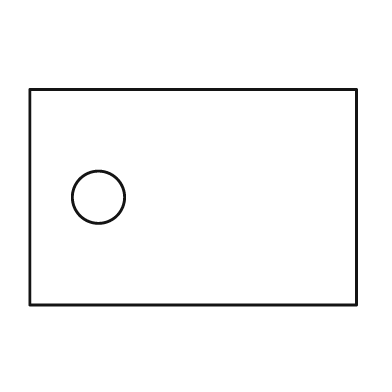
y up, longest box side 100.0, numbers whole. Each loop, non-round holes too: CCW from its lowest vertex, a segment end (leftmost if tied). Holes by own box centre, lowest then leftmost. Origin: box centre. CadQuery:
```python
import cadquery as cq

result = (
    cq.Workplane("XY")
    .moveTo(-50.0, -33.0)
    .lineTo(50.0, -33.0)
    .lineTo(50.0, 33.0)
    .lineTo(-50.0, 33.0)
    .close()
    .moveTo(-29.0, 0.0)
    .circle(8.0)
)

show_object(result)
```